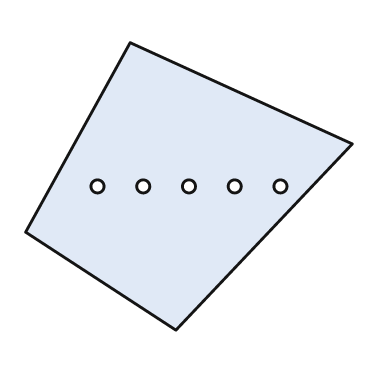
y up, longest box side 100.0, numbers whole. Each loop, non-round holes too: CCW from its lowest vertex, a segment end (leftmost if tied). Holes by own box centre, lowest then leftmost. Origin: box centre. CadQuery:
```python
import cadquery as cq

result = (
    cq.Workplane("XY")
    .moveTo(-4.0, -44.0)
    .lineTo(50.0, 13.0)
    .lineTo(-18.0, 44.0)
    .lineTo(-50.0, -14.0)
    .close()
    .moveTo(-28.0, 0.0)
    .circle(2.0)
    .moveTo(-14.0, 0.0)
    .circle(2.0)
    .moveTo(0.0, 0.0)
    .circle(2.0)
    .moveTo(14.0, 0.0)
    .circle(2.0)
    .moveTo(28.0, 0.0)
    .circle(2.0)
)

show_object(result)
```